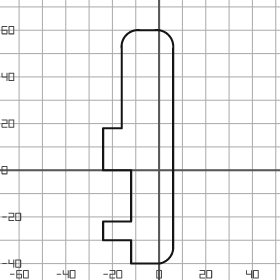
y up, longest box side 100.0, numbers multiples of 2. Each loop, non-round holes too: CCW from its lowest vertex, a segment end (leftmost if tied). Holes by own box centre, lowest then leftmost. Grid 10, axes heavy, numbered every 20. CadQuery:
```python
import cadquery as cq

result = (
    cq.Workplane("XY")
    .moveTo(-12.0, -40.0)
    .lineTo(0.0, -40.0)
    .threePointArc((4.0, -38.0), (6.0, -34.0))
    .lineTo(6.0, 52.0)
    .threePointArc((4.0, 58.0), (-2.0, 60.0))
    .lineTo(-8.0, 60.0)
    .threePointArc((-14.0, 58.0), (-16.0, 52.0))
    .lineTo(-16.0, 18.0)
    .lineTo(-24.0, 18.0)
    .lineTo(-24.0, 0.0)
    .lineTo(-12.0, 0.0)
    .lineTo(-12.0, -22.0)
    .lineTo(-24.0, -22.0)
    .lineTo(-24.0, -30.0)
    .lineTo(-12.0, -30.0)
    .close()
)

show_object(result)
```